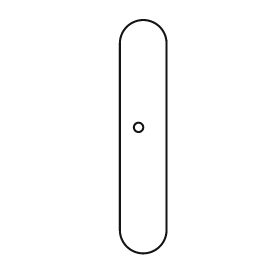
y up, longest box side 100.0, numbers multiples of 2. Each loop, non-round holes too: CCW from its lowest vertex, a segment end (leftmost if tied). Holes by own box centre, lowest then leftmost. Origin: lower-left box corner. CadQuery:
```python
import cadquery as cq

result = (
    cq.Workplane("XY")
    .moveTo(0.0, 10.0)
    .threePointArc((10.0, 0.0), (20.0, 10.0))
    .lineTo(20.0, 90.0)
    .threePointArc((10.0, 100.0), (0.0, 90.0))
    .close()
    .moveTo(8.0, 54.0)
    .circle(2.0)
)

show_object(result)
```